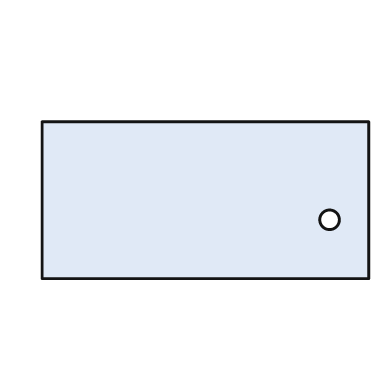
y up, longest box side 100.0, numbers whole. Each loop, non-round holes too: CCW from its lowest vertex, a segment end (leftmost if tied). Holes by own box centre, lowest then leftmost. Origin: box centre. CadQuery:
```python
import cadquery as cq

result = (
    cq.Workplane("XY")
    .moveTo(-50.0, -24.0)
    .lineTo(50.0, -24.0)
    .lineTo(50.0, 24.0)
    .lineTo(-50.0, 24.0)
    .close()
    .moveTo(38.0, -6.0)
    .circle(3.0)
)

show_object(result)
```